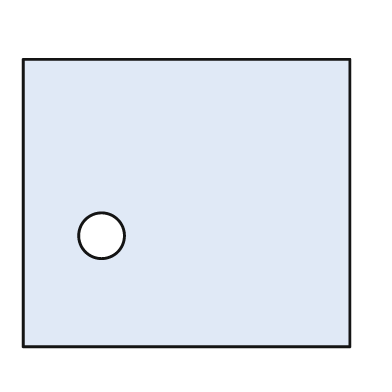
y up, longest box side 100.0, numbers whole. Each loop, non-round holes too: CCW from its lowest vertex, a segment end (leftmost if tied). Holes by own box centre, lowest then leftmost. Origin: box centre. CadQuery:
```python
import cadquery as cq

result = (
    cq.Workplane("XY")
    .moveTo(-50.0, -44.0)
    .lineTo(50.0, -44.0)
    .lineTo(50.0, 44.0)
    .lineTo(-50.0, 44.0)
    .close()
    .moveTo(-26.0, -10.0)
    .circle(7.0)
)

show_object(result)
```